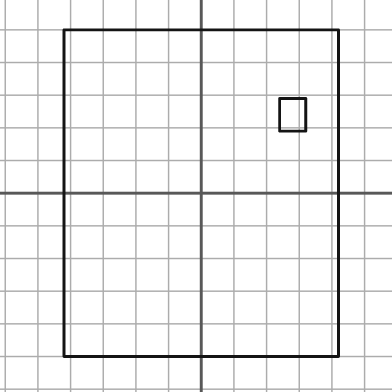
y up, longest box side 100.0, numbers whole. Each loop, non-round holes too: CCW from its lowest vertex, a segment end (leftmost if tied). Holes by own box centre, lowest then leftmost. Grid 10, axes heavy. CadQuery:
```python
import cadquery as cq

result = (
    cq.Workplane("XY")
    .moveTo(-42.0, -50.0)
    .lineTo(42.0, -50.0)
    .lineTo(42.0, 50.0)
    .lineTo(-42.0, 50.0)
    .close()
    .moveTo(24.0, 19.0)
    .lineTo(32.0, 19.0)
    .lineTo(32.0, 29.0)
    .lineTo(24.0, 29.0)
    .close()
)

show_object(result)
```